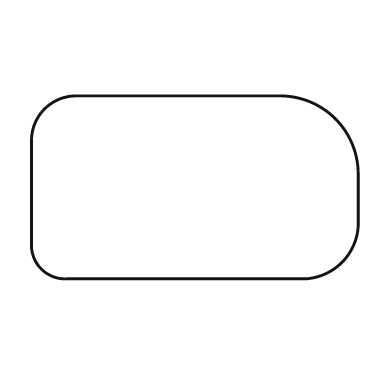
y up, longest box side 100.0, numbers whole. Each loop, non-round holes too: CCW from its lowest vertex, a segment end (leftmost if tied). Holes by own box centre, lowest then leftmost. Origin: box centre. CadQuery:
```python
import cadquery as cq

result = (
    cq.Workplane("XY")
    .moveTo(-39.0, -28.0)
    .lineTo(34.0, -28.0)
    .threePointArc((45.0, -23.0), (50.0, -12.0))
    .lineTo(50.0, 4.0)
    .threePointArc((43.0, 21.0), (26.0, 28.0))
    .lineTo(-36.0, 28.0)
    .threePointArc((-46.0, 24.0), (-50.0, 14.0))
    .lineTo(-50.0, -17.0)
    .threePointArc((-47.0, -25.0), (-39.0, -28.0))
    .close()
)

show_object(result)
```